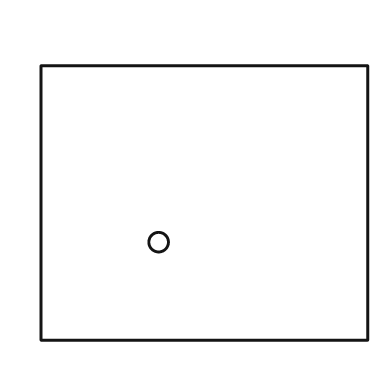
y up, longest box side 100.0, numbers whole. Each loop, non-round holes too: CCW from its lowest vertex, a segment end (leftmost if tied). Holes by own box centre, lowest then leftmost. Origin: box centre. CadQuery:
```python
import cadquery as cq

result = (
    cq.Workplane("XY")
    .moveTo(-50.0, -42.0)
    .lineTo(50.0, -42.0)
    .lineTo(50.0, 42.0)
    .lineTo(-50.0, 42.0)
    .close()
    .moveTo(-14.0, -12.0)
    .circle(3.0)
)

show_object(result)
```